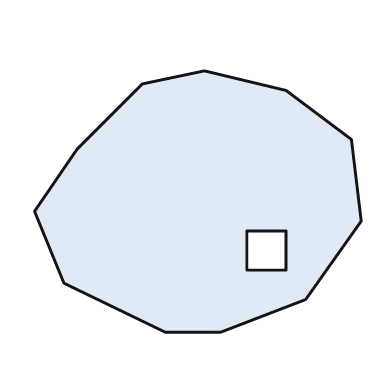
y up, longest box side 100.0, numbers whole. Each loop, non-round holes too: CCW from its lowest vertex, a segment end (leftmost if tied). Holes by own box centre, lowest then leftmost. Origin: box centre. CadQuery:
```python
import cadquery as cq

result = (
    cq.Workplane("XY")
    .moveTo(-10.0, -40.0)
    .lineTo(7.0, -40.0)
    .lineTo(33.0, -30.0)
    .lineTo(50.0, -6.0)
    .lineTo(47.0, 19.0)
    .lineTo(27.0, 34.0)
    .lineTo(2.0, 40.0)
    .lineTo(-17.0, 36.0)
    .lineTo(-37.0, 16.0)
    .lineTo(-50.0, -3.0)
    .lineTo(-41.0, -25.0)
    .close()
    .moveTo(15.0, -21.0)
    .lineTo(27.0, -21.0)
    .lineTo(27.0, -9.0)
    .lineTo(15.0, -9.0)
    .close()
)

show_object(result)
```